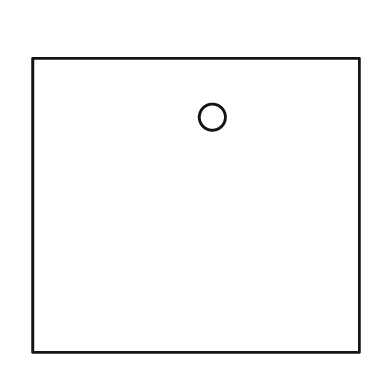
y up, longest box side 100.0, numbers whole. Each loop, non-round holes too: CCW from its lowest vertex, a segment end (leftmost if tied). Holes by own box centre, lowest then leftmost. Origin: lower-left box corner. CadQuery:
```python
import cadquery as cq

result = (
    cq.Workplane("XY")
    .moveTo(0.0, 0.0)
    .lineTo(100.0, 0.0)
    .lineTo(100.0, 90.0)
    .lineTo(0.0, 90.0)
    .close()
    .moveTo(55.0, 72.0)
    .circle(4.0)
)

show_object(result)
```